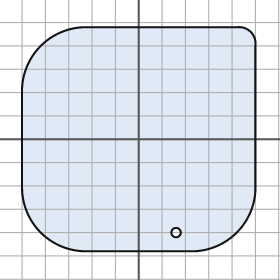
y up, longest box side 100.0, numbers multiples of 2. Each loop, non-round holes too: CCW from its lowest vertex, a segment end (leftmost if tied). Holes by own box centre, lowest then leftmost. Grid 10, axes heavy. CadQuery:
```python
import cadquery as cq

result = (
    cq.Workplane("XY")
    .moveTo(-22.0, -48.0)
    .lineTo(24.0, -48.0)
    .threePointArc((42.0, -40.0), (50.0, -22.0))
    .lineTo(50.0, 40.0)
    .threePointArc((48.0, 46.0), (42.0, 48.0))
    .lineTo(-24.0, 48.0)
    .threePointArc((-42.0, 40.0), (-50.0, 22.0))
    .lineTo(-50.0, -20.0)
    .threePointArc((-42.0, -40.0), (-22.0, -48.0))
    .close()
    .moveTo(16.0, -40.0)
    .circle(2.0)
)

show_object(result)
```